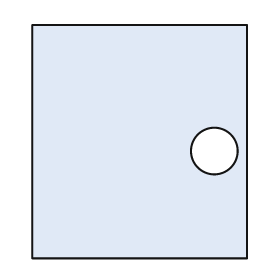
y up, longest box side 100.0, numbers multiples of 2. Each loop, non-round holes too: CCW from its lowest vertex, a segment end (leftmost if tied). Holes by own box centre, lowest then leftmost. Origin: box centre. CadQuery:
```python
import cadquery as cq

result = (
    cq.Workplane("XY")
    .moveTo(-46.0, -50.0)
    .lineTo(46.0, -50.0)
    .lineTo(46.0, 50.0)
    .lineTo(-46.0, 50.0)
    .close()
    .moveTo(32.0, -4.0)
    .circle(10.0)
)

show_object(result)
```